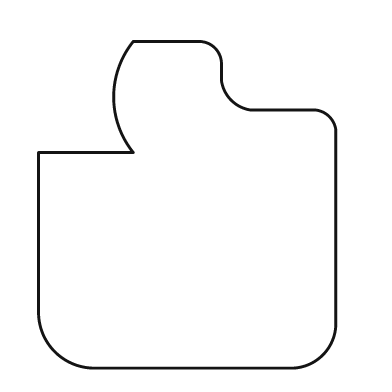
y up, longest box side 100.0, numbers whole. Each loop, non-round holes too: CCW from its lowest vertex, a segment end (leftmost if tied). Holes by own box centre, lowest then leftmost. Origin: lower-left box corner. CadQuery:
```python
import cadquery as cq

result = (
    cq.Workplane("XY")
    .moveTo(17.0, 0.0)
    .lineTo(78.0, 0.0)
    .threePointArc((87.0, 4.0), (91.0, 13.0))
    .lineTo(91.0, 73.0)
    .threePointArc((89.0, 77.0), (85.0, 79.0))
    .lineTo(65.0, 79.0)
    .threePointArc((59.0, 82.0), (56.0, 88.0))
    .lineTo(56.0, 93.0)
    .threePointArc((54.0, 98.0), (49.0, 100.0))
    .lineTo(29.0, 100.0)
    .threePointArc((23.0, 83.0), (29.0, 66.0))
    .lineTo(0.0, 66.0)
    .lineTo(0.0, 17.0)
    .threePointArc((5.0, 5.0), (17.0, 0.0))
    .close()
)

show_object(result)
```